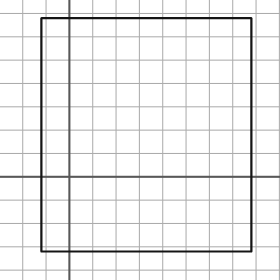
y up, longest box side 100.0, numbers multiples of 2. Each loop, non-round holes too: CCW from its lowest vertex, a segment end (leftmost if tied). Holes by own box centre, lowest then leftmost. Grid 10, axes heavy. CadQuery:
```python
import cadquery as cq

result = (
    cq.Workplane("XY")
    .moveTo(-12.0, -32.0)
    .lineTo(78.0, -32.0)
    .lineTo(78.0, 68.0)
    .lineTo(-12.0, 68.0)
    .close()
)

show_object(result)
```